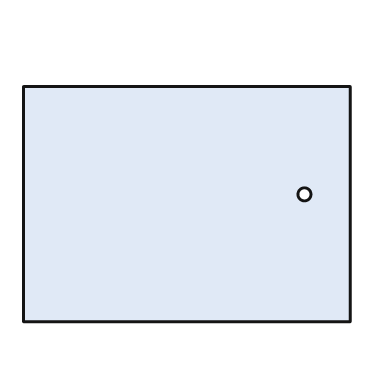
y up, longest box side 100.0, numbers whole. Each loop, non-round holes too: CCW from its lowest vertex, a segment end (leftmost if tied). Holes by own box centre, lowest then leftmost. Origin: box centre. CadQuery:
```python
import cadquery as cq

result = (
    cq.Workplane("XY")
    .moveTo(-50.0, -36.0)
    .lineTo(50.0, -36.0)
    .lineTo(50.0, 36.0)
    .lineTo(-50.0, 36.0)
    .close()
    .moveTo(36.0, 3.0)
    .circle(2.0)
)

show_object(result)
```